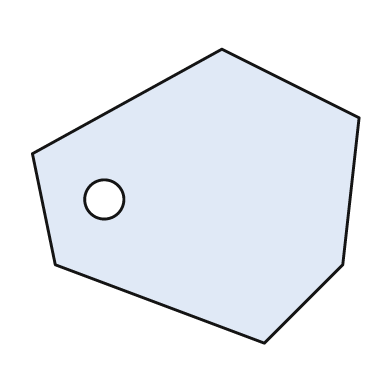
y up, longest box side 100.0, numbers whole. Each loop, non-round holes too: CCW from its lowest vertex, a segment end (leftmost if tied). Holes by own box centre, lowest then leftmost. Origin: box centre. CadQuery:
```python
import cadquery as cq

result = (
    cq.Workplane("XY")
    .moveTo(21.0, -45.0)
    .lineTo(45.0, -21.0)
    .lineTo(50.0, 24.0)
    .lineTo(8.0, 45.0)
    .lineTo(-50.0, 13.0)
    .lineTo(-43.0, -21.0)
    .close()
    .moveTo(-28.0, -1.0)
    .circle(6.0)
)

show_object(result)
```